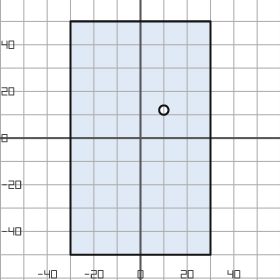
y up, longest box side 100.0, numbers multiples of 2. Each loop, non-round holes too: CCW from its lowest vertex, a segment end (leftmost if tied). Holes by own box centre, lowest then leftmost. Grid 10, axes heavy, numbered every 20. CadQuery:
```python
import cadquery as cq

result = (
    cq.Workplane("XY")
    .moveTo(-30.0, -50.0)
    .lineTo(30.0, -50.0)
    .lineTo(30.0, 50.0)
    .lineTo(-30.0, 50.0)
    .close()
    .moveTo(10.0, 12.0)
    .circle(2.0)
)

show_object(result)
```